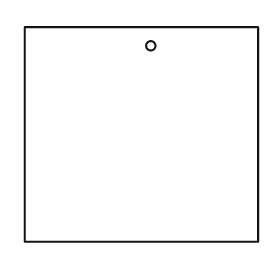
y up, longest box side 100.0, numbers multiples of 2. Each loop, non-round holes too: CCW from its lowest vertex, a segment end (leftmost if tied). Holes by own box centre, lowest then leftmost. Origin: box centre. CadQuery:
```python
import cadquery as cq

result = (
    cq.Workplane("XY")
    .moveTo(-50.0, -46.0)
    .lineTo(50.0, -46.0)
    .lineTo(50.0, 46.0)
    .lineTo(-50.0, 46.0)
    .close()
    .moveTo(4.0, 38.0)
    .circle(2.0)
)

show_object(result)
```